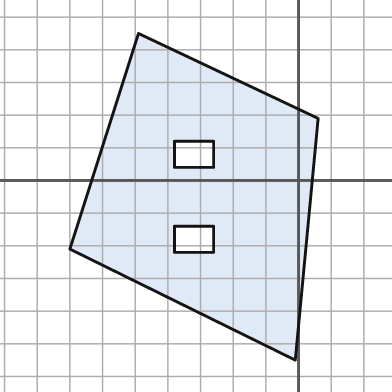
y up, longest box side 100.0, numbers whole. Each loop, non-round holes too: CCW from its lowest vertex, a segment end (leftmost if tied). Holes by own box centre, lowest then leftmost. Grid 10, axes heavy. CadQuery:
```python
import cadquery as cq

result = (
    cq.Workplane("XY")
    .moveTo(-1.0, -55.0)
    .lineTo(6.0, 19.0)
    .lineTo(-49.0, 45.0)
    .lineTo(-70.0, -21.0)
    .close()
    .moveTo(-38.0, -22.0)
    .lineTo(-26.0, -22.0)
    .lineTo(-26.0, -14.0)
    .lineTo(-38.0, -14.0)
    .close()
    .moveTo(-38.0, 4.0)
    .lineTo(-26.0, 4.0)
    .lineTo(-26.0, 12.0)
    .lineTo(-38.0, 12.0)
    .close()
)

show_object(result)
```